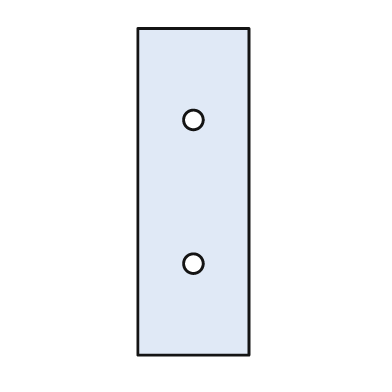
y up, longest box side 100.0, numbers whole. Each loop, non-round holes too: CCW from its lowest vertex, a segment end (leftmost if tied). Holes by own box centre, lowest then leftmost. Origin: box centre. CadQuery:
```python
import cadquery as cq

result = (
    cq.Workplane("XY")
    .moveTo(-17.0, -50.0)
    .lineTo(17.0, -50.0)
    .lineTo(17.0, 50.0)
    .lineTo(-17.0, 50.0)
    .close()
    .moveTo(0.0, -22.0)
    .circle(3.0)
    .moveTo(0.0, 22.0)
    .circle(3.0)
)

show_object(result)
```